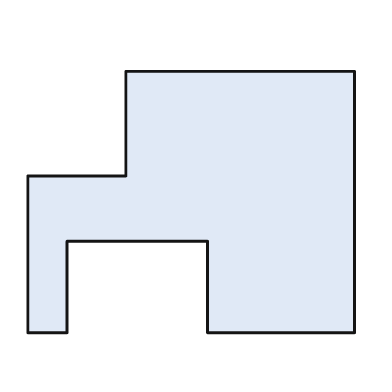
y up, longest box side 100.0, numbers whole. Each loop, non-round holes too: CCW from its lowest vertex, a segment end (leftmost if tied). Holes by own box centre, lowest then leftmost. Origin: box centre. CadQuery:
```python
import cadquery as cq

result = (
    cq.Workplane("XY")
    .moveTo(-50.0, -40.0)
    .lineTo(-38.0, -40.0)
    .lineTo(-38.0, -12.0)
    .lineTo(5.0, -12.0)
    .lineTo(5.0, -40.0)
    .lineTo(50.0, -40.0)
    .lineTo(50.0, 40.0)
    .lineTo(-20.0, 40.0)
    .lineTo(-20.0, 8.0)
    .lineTo(-50.0, 8.0)
    .close()
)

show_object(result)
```